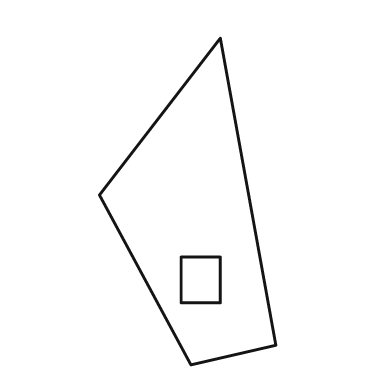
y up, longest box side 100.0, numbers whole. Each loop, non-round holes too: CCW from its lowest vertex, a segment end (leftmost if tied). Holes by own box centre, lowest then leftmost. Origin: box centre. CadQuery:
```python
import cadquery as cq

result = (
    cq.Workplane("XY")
    .moveTo(1.0, -50.0)
    .lineTo(27.0, -44.0)
    .lineTo(10.0, 50.0)
    .lineTo(-27.0, 2.0)
    .close()
    .moveTo(-2.0, -31.0)
    .lineTo(10.0, -31.0)
    .lineTo(10.0, -17.0)
    .lineTo(-2.0, -17.0)
    .close()
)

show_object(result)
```